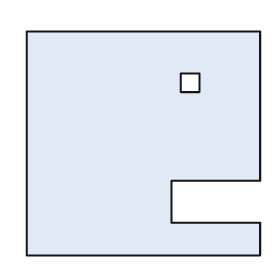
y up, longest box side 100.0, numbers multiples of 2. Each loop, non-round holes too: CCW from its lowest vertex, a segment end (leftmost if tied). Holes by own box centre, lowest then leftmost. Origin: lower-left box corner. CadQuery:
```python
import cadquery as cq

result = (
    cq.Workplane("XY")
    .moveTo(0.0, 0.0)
    .lineTo(100.0, 0.0)
    .lineTo(100.0, 14.0)
    .lineTo(62.0, 14.0)
    .lineTo(62.0, 32.0)
    .lineTo(100.0, 32.0)
    .lineTo(100.0, 96.0)
    .lineTo(0.0, 96.0)
    .close()
    .moveTo(66.0, 70.0)
    .lineTo(74.0, 70.0)
    .lineTo(74.0, 78.0)
    .lineTo(66.0, 78.0)
    .close()
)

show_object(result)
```